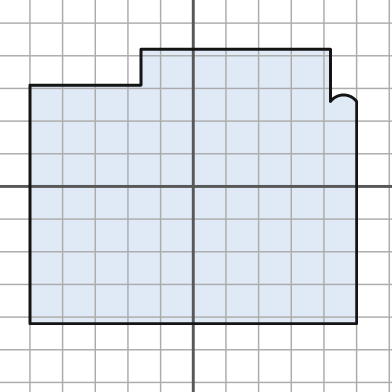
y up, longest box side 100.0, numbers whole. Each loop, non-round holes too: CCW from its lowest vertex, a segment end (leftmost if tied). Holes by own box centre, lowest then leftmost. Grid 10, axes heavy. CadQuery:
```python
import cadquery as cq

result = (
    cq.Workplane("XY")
    .moveTo(-50.0, -42.0)
    .lineTo(50.0, -42.0)
    .lineTo(50.0, 26.0)
    .threePointArc((46.0, 28.0), (42.0, 26.0))
    .lineTo(42.0, 42.0)
    .lineTo(-16.0, 42.0)
    .lineTo(-16.0, 31.0)
    .lineTo(-50.0, 31.0)
    .close()
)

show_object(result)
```